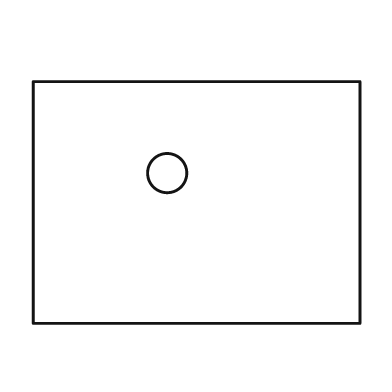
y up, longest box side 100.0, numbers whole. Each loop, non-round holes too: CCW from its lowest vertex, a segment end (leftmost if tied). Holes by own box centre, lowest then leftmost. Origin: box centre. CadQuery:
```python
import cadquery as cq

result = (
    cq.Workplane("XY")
    .moveTo(-50.0, -37.0)
    .lineTo(50.0, -37.0)
    .lineTo(50.0, 37.0)
    .lineTo(-50.0, 37.0)
    .close()
    .moveTo(-9.0, 9.0)
    .circle(6.0)
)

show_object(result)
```